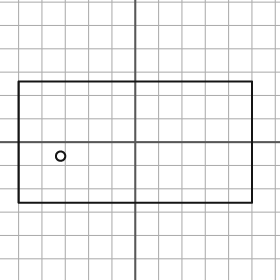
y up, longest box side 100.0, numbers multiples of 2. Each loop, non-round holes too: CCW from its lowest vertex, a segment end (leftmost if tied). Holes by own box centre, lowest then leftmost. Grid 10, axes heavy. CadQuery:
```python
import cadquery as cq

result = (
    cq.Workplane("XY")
    .moveTo(-50.0, -26.0)
    .lineTo(50.0, -26.0)
    .lineTo(50.0, 26.0)
    .lineTo(-50.0, 26.0)
    .close()
    .moveTo(-32.0, -6.0)
    .circle(2.0)
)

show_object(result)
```